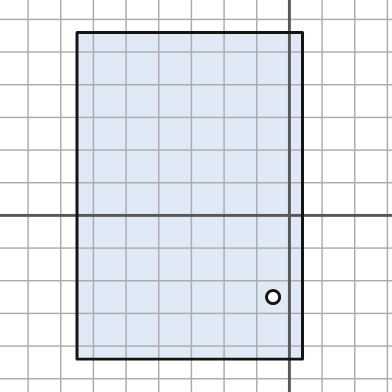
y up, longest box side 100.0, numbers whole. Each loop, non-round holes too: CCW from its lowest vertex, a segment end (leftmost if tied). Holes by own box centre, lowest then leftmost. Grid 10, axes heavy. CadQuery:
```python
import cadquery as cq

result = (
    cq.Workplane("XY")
    .moveTo(-65.0, -44.0)
    .lineTo(4.0, -44.0)
    .lineTo(4.0, 56.0)
    .lineTo(-65.0, 56.0)
    .close()
    .moveTo(-5.0, -25.0)
    .circle(2.0)
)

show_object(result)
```